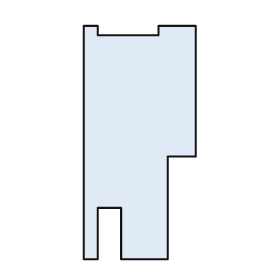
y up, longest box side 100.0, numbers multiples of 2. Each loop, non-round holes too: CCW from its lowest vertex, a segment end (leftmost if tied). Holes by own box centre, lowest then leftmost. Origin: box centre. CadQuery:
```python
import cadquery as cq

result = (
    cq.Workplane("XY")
    .moveTo(-24.0, -50.0)
    .lineTo(-18.0, -50.0)
    .lineTo(-18.0, -28.0)
    .lineTo(-8.0, -28.0)
    .lineTo(-8.0, -50.0)
    .lineTo(12.0, -50.0)
    .lineTo(12.0, -6.0)
    .lineTo(24.0, -6.0)
    .lineTo(24.0, 50.0)
    .lineTo(8.0, 50.0)
    .lineTo(8.0, 46.0)
    .lineTo(-18.0, 46.0)
    .lineTo(-18.0, 50.0)
    .lineTo(-24.0, 50.0)
    .close()
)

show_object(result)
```